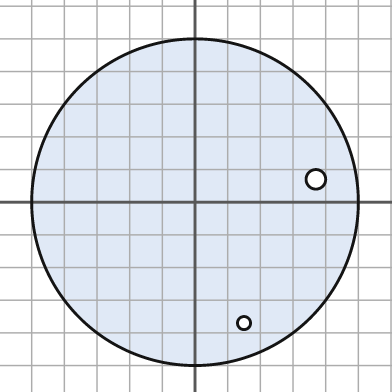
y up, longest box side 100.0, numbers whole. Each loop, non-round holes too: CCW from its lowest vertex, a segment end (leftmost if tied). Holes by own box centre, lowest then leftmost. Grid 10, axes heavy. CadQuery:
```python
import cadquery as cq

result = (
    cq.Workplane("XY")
    .moveTo(0.0, 0.0)
    .circle(50.0)
    .moveTo(15.0, -37.0)
    .circle(2.0)
    .moveTo(37.0, 7.0)
    .circle(3.0)
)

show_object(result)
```